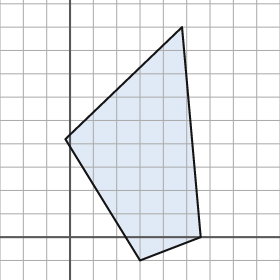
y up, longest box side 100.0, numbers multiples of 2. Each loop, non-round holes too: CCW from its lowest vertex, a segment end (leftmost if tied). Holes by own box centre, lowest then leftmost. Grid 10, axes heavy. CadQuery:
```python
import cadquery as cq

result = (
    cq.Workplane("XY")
    .moveTo(30.0, -10.0)
    .lineTo(56.0, 0.0)
    .lineTo(48.0, 90.0)
    .lineTo(-2.0, 42.0)
    .close()
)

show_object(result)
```